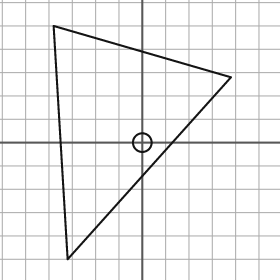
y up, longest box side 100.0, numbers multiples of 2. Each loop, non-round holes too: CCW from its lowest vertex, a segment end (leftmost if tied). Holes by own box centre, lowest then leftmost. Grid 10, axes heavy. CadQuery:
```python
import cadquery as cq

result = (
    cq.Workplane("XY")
    .moveTo(-32.0, -50.0)
    .lineTo(38.0, 28.0)
    .lineTo(-38.0, 50.0)
    .close()
    .moveTo(0.0, 0.0)
    .circle(4.0)
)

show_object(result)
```